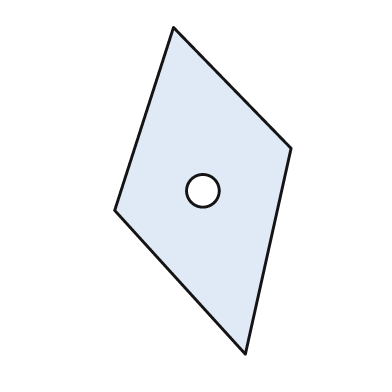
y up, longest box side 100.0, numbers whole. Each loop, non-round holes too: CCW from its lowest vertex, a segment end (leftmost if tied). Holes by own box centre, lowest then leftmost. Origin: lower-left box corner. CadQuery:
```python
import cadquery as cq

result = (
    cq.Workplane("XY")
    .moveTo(40.0, 0.0)
    .lineTo(54.0, 63.0)
    .lineTo(18.0, 100.0)
    .lineTo(0.0, 44.0)
    .close()
    .moveTo(27.0, 50.0)
    .circle(5.0)
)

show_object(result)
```